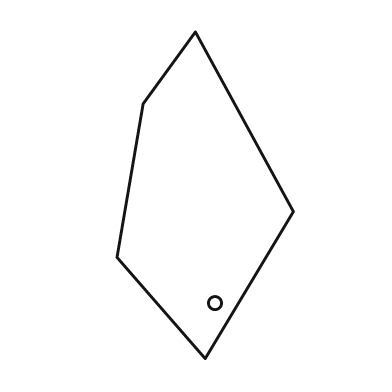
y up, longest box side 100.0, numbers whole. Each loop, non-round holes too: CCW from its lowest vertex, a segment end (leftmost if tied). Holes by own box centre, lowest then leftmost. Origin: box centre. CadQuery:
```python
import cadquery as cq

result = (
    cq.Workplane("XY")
    .moveTo(0.0, -50.0)
    .lineTo(27.0, -5.0)
    .lineTo(-3.0, 50.0)
    .lineTo(-19.0, 28.0)
    .lineTo(-27.0, -19.0)
    .close()
    .moveTo(3.0, -33.0)
    .circle(2.0)
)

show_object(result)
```